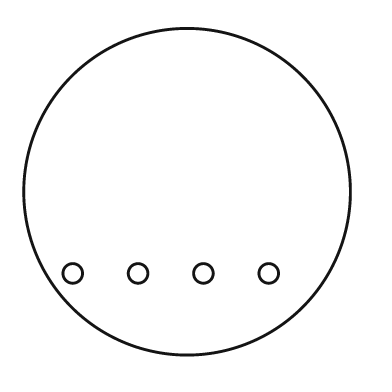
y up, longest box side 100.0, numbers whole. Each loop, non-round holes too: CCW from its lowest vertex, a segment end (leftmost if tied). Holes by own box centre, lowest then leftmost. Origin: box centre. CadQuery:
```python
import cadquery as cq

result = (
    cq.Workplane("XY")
    .moveTo(0.0, 0.0)
    .circle(50.0)
    .moveTo(-35.0, -25.0)
    .circle(3.0)
    .moveTo(-15.0, -25.0)
    .circle(3.0)
    .moveTo(5.0, -25.0)
    .circle(3.0)
    .moveTo(25.0, -25.0)
    .circle(3.0)
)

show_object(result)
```